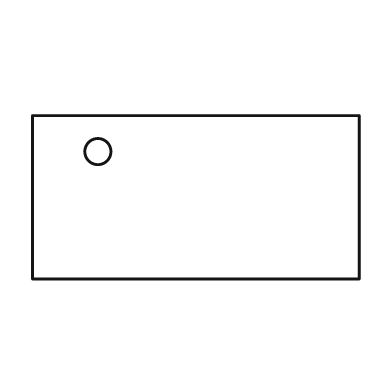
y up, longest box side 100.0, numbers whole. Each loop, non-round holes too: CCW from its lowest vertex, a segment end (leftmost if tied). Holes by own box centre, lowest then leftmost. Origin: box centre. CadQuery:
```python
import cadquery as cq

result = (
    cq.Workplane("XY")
    .moveTo(-50.0, -25.0)
    .lineTo(50.0, -25.0)
    .lineTo(50.0, 25.0)
    .lineTo(-50.0, 25.0)
    .close()
    .moveTo(-30.0, 14.0)
    .circle(4.0)
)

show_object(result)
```